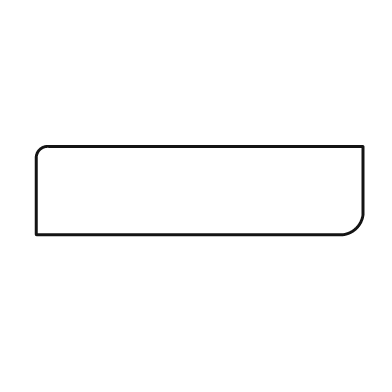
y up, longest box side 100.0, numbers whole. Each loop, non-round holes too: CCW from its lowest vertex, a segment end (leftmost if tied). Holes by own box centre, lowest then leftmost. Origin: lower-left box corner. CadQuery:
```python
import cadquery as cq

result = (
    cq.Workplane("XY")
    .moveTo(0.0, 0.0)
    .lineTo(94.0, 0.0)
    .threePointArc((98.0, 2.0), (100.0, 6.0))
    .lineTo(100.0, 27.0)
    .lineTo(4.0, 27.0)
    .threePointArc((1.0, 26.0), (0.0, 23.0))
    .close()
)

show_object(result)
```